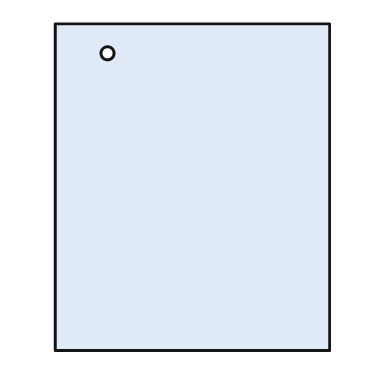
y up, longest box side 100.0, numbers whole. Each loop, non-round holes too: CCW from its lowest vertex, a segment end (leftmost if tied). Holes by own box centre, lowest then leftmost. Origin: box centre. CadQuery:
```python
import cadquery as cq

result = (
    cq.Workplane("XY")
    .moveTo(-42.0, -50.0)
    .lineTo(42.0, -50.0)
    .lineTo(42.0, 50.0)
    .lineTo(-42.0, 50.0)
    .close()
    .moveTo(-26.0, 41.0)
    .circle(2.0)
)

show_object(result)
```